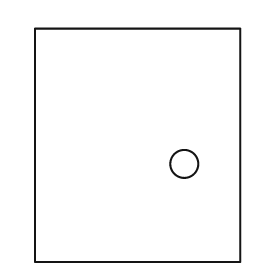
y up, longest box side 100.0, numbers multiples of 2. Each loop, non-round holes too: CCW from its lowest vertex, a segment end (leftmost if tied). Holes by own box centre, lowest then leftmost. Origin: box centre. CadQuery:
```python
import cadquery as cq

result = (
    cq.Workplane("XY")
    .moveTo(-44.0, -50.0)
    .lineTo(44.0, -50.0)
    .lineTo(44.0, 50.0)
    .lineTo(-44.0, 50.0)
    .close()
    .moveTo(20.0, -8.0)
    .circle(6.0)
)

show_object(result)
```